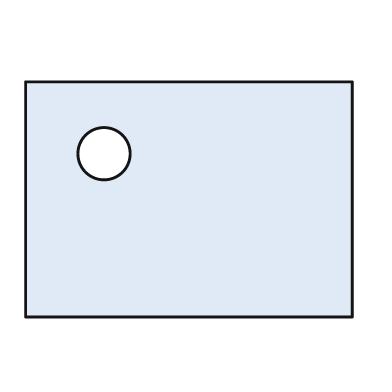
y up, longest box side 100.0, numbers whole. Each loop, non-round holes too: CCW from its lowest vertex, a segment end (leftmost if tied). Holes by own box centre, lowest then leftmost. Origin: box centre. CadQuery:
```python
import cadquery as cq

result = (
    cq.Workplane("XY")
    .moveTo(-50.0, -36.0)
    .lineTo(50.0, -36.0)
    .lineTo(50.0, 36.0)
    .lineTo(-50.0, 36.0)
    .close()
    .moveTo(-26.0, 14.0)
    .circle(8.0)
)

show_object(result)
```